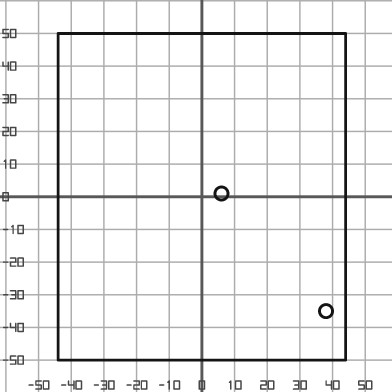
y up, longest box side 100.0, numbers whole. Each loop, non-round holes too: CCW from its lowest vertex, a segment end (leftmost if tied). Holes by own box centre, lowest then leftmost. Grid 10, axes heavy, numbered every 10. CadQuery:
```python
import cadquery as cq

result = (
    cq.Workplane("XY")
    .moveTo(-44.0, -50.0)
    .lineTo(44.0, -50.0)
    .lineTo(44.0, 50.0)
    .lineTo(-44.0, 50.0)
    .close()
    .moveTo(38.0, -35.0)
    .circle(2.0)
    .moveTo(6.0, 1.0)
    .circle(2.0)
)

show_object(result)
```